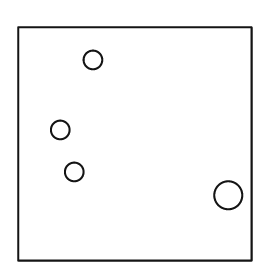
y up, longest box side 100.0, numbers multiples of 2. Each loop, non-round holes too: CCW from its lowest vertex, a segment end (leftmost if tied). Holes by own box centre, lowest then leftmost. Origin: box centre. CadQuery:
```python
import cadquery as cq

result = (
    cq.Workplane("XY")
    .moveTo(-50.0, -50.0)
    .lineTo(50.0, -50.0)
    .lineTo(50.0, 50.0)
    .lineTo(-50.0, 50.0)
    .close()
    .moveTo(40.0, -22.0)
    .circle(6.0)
    .moveTo(-26.0, -12.0)
    .circle(4.0)
    .moveTo(-32.0, 6.0)
    .circle(4.0)
    .moveTo(-18.0, 36.0)
    .circle(4.0)
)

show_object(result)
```